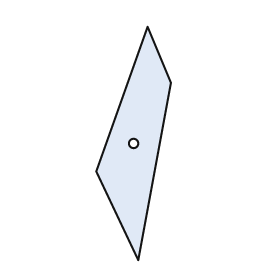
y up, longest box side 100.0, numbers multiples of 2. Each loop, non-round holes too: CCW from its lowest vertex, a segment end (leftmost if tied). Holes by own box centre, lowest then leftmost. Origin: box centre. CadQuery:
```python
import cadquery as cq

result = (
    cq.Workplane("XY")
    .moveTo(2.0, -50.0)
    .lineTo(16.0, 26.0)
    .lineTo(6.0, 50.0)
    .lineTo(-16.0, -12.0)
    .close()
    .moveTo(0.0, 0.0)
    .circle(2.0)
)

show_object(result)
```